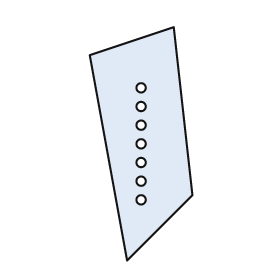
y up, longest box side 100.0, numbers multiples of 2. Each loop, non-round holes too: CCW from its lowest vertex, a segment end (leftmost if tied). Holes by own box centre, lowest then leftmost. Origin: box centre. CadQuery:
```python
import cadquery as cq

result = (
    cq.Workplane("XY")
    .moveTo(-6.0, -50.0)
    .lineTo(22.0, -22.0)
    .lineTo(14.0, 50.0)
    .lineTo(-22.0, 38.0)
    .close()
    .moveTo(0.0, -24.0)
    .circle(2.0)
    .moveTo(0.0, -16.0)
    .circle(2.0)
    .moveTo(0.0, -8.0)
    .circle(2.0)
    .moveTo(0.0, 0.0)
    .circle(2.0)
    .moveTo(0.0, 8.0)
    .circle(2.0)
    .moveTo(0.0, 16.0)
    .circle(2.0)
    .moveTo(0.0, 24.0)
    .circle(2.0)
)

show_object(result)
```